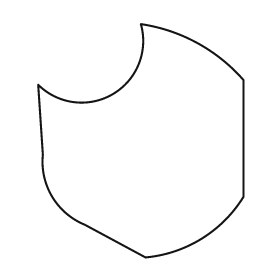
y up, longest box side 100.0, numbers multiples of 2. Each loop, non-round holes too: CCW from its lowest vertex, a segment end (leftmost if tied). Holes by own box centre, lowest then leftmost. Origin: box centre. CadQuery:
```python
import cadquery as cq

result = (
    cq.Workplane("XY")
    .moveTo(2.0, -50.0)
    .threePointArc((26.0, -42.0), (44.0, -24.0))
    .lineTo(44.0, 26.0)
    .threePointArc((24.0, 42.0), (0.0, 50.0))
    .threePointArc((-12.0, 20.0), (-44.0, 24.0))
    .lineTo(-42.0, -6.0)
    .threePointArc((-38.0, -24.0), (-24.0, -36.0))
    .close()
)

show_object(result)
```